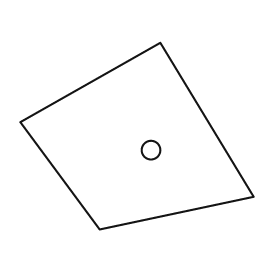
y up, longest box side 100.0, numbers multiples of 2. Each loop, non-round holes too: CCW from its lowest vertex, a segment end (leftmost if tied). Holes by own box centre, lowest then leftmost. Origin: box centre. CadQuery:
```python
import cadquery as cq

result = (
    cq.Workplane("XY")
    .moveTo(-16.0, -40.0)
    .lineTo(50.0, -26.0)
    .lineTo(10.0, 40.0)
    .lineTo(-50.0, 6.0)
    .close()
    .moveTo(6.0, -6.0)
    .circle(4.0)
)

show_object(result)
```